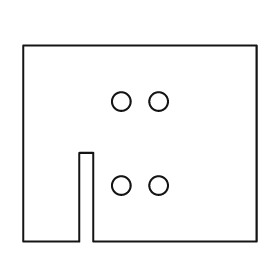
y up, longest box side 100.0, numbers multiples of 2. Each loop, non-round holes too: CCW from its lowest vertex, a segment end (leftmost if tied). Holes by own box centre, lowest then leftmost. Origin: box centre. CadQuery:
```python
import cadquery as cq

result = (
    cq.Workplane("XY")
    .moveTo(-50.0, -42.0)
    .lineTo(-26.0, -42.0)
    .lineTo(-26.0, -4.0)
    .lineTo(-20.0, -4.0)
    .lineTo(-20.0, -42.0)
    .lineTo(50.0, -42.0)
    .lineTo(50.0, 42.0)
    .lineTo(-50.0, 42.0)
    .close()
    .moveTo(-8.0, -18.0)
    .circle(4.0)
    .moveTo(8.0, -18.0)
    .circle(4.0)
    .moveTo(-8.0, 18.0)
    .circle(4.0)
    .moveTo(8.0, 18.0)
    .circle(4.0)
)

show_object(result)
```